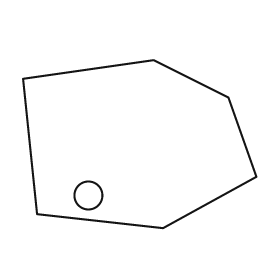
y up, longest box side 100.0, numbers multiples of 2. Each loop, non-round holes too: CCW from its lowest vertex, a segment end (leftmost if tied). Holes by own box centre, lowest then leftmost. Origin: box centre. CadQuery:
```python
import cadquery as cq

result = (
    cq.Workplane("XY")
    .moveTo(10.0, -36.0)
    .lineTo(50.0, -14.0)
    .lineTo(38.0, 20.0)
    .lineTo(6.0, 36.0)
    .lineTo(-50.0, 28.0)
    .lineTo(-44.0, -30.0)
    .close()
    .moveTo(-22.0, -22.0)
    .circle(6.0)
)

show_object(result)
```